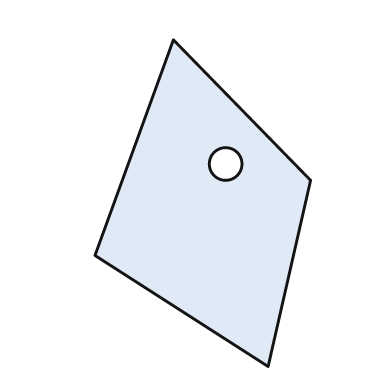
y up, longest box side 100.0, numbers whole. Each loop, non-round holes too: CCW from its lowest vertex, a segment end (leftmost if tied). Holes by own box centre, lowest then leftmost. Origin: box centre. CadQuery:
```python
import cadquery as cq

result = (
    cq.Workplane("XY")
    .moveTo(20.0, -50.0)
    .lineTo(33.0, 7.0)
    .lineTo(-9.0, 50.0)
    .lineTo(-33.0, -16.0)
    .close()
    .moveTo(7.0, 12.0)
    .circle(5.0)
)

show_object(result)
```